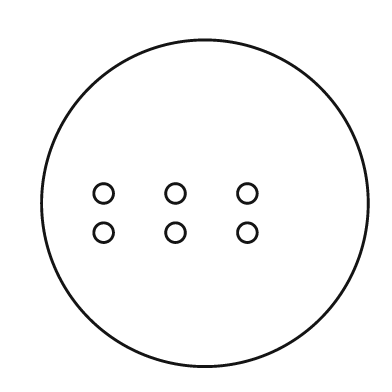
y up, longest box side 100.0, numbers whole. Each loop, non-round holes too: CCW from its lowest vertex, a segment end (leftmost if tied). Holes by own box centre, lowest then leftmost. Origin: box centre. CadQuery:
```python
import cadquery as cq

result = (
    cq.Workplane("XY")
    .moveTo(0.0, 0.0)
    .circle(50.0)
    .moveTo(-31.0, -9.0)
    .circle(3.0)
    .moveTo(-9.0, -9.0)
    .circle(3.0)
    .moveTo(13.0, -9.0)
    .circle(3.0)
    .moveTo(-31.0, 3.0)
    .circle(3.0)
    .moveTo(-9.0, 3.0)
    .circle(3.0)
    .moveTo(13.0, 3.0)
    .circle(3.0)
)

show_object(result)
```